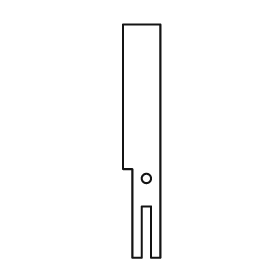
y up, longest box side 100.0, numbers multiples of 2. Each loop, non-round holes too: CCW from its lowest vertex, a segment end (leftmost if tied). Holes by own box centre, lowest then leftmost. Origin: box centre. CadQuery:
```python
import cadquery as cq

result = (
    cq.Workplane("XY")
    .moveTo(-4.0, -50.0)
    .lineTo(0.0, -50.0)
    .lineTo(0.0, -28.0)
    .lineTo(4.0, -28.0)
    .lineTo(4.0, -50.0)
    .lineTo(8.0, -50.0)
    .lineTo(8.0, 50.0)
    .lineTo(-8.0, 50.0)
    .lineTo(-8.0, -12.0)
    .lineTo(-4.0, -12.0)
    .close()
    .moveTo(2.0, -16.0)
    .circle(2.0)
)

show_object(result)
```